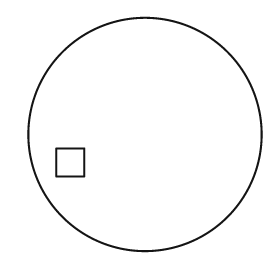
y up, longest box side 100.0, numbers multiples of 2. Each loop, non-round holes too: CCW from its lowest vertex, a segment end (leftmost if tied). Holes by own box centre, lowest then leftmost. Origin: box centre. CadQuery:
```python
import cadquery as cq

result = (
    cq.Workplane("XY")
    .moveTo(0.0, 0.0)
    .circle(50.0)
    .moveTo(-38.0, -18.0)
    .lineTo(-26.0, -18.0)
    .lineTo(-26.0, -6.0)
    .lineTo(-38.0, -6.0)
    .close()
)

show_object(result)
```